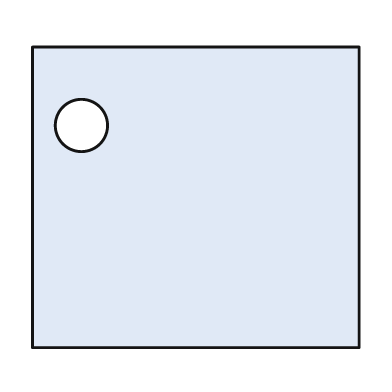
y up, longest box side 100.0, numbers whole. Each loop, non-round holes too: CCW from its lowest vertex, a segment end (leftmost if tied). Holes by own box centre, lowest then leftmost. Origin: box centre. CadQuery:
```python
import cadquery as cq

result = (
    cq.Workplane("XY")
    .moveTo(-50.0, -46.0)
    .lineTo(50.0, -46.0)
    .lineTo(50.0, 46.0)
    .lineTo(-50.0, 46.0)
    .close()
    .moveTo(-35.0, 22.0)
    .circle(8.0)
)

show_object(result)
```